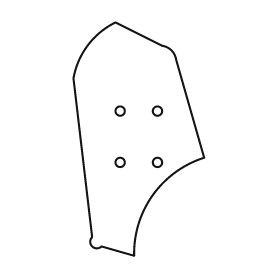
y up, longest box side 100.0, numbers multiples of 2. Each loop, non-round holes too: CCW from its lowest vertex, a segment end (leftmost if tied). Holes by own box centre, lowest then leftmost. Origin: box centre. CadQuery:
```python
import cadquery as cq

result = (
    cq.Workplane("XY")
    .moveTo(-2.0, -50.0)
    .threePointArc((6.0, -24.0), (28.0, -8.0))
    .lineTo(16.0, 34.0)
    .threePointArc((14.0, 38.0), (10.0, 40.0))
    .lineTo(-10.0, 50.0)
    .threePointArc((-22.0, 40.0), (-28.0, 26.0))
    .lineTo(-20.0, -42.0)
    .threePointArc((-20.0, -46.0), (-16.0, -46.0))
    .close()
    .moveTo(-8.0, -10.0)
    .circle(2.0)
    .moveTo(8.0, -10.0)
    .circle(2.0)
    .moveTo(-8.0, 12.0)
    .circle(2.0)
    .moveTo(8.0, 12.0)
    .circle(2.0)
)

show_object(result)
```